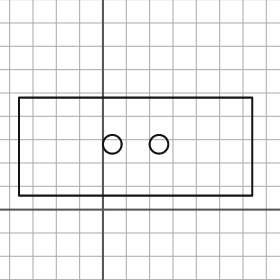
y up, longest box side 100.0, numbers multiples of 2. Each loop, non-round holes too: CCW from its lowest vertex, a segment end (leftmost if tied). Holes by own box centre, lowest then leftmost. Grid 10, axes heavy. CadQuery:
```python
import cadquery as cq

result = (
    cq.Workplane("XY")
    .moveTo(-36.0, 6.0)
    .lineTo(64.0, 6.0)
    .lineTo(64.0, 48.0)
    .lineTo(-36.0, 48.0)
    .close()
    .moveTo(4.0, 28.0)
    .circle(4.0)
    .moveTo(24.0, 28.0)
    .circle(4.0)
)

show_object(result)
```